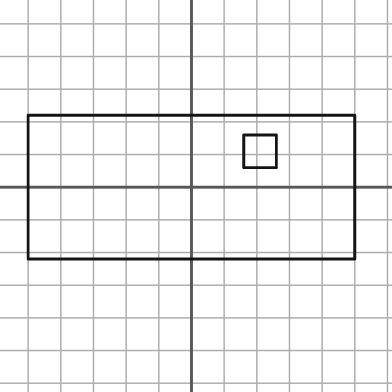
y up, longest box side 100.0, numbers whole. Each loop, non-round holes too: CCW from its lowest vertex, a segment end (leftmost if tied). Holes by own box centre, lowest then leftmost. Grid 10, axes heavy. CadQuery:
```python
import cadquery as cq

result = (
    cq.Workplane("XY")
    .moveTo(-50.0, -22.0)
    .lineTo(50.0, -22.0)
    .lineTo(50.0, 22.0)
    .lineTo(-50.0, 22.0)
    .close()
    .moveTo(16.0, 6.0)
    .lineTo(26.0, 6.0)
    .lineTo(26.0, 16.0)
    .lineTo(16.0, 16.0)
    .close()
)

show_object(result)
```